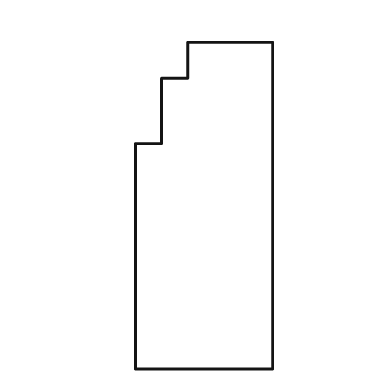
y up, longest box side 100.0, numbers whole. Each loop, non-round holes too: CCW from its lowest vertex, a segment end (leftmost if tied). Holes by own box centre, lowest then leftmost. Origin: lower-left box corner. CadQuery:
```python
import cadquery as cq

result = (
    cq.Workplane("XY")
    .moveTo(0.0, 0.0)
    .lineTo(42.0, 0.0)
    .lineTo(42.0, 100.0)
    .lineTo(16.0, 100.0)
    .lineTo(16.0, 89.0)
    .lineTo(8.0, 89.0)
    .lineTo(8.0, 69.0)
    .lineTo(0.0, 69.0)
    .close()
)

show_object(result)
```